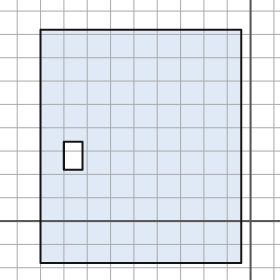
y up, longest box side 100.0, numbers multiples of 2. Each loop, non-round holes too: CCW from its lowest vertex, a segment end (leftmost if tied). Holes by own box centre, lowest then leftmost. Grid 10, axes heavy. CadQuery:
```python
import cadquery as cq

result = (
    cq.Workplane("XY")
    .moveTo(-90.0, -18.0)
    .lineTo(-4.0, -18.0)
    .lineTo(-4.0, 82.0)
    .lineTo(-90.0, 82.0)
    .close()
    .moveTo(-80.0, 22.0)
    .lineTo(-72.0, 22.0)
    .lineTo(-72.0, 34.0)
    .lineTo(-80.0, 34.0)
    .close()
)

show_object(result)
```